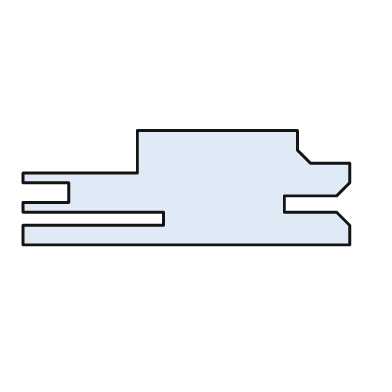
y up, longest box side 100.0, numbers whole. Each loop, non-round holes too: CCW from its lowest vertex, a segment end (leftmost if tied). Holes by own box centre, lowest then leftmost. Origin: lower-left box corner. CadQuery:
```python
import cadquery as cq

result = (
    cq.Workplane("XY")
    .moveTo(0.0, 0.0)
    .lineTo(100.0, 0.0)
    .lineTo(100.0, 6.0)
    .lineTo(96.0, 10.0)
    .lineTo(80.0, 10.0)
    .lineTo(80.0, 15.0)
    .lineTo(96.0, 15.0)
    .lineTo(100.0, 19.0)
    .lineTo(100.0, 25.0)
    .lineTo(88.0, 25.0)
    .lineTo(84.0, 29.0)
    .lineTo(84.0, 35.0)
    .lineTo(35.0, 35.0)
    .lineTo(35.0, 22.0)
    .lineTo(0.0, 22.0)
    .lineTo(0.0, 19.0)
    .lineTo(14.0, 19.0)
    .lineTo(14.0, 13.0)
    .lineTo(0.0, 13.0)
    .lineTo(0.0, 10.0)
    .lineTo(43.0, 10.0)
    .lineTo(43.0, 6.0)
    .lineTo(0.0, 6.0)
    .close()
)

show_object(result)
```